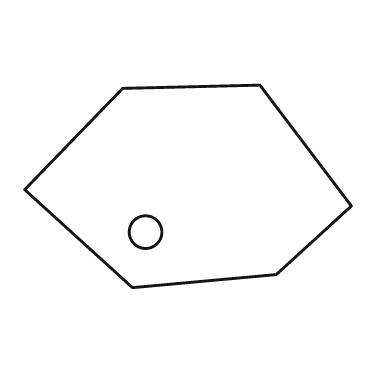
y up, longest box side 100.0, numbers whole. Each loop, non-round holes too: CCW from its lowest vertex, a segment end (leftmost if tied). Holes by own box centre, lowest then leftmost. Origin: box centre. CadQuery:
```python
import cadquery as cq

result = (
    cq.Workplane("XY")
    .moveTo(-17.0, -31.0)
    .lineTo(27.0, -27.0)
    .lineTo(50.0, -6.0)
    .lineTo(22.0, 31.0)
    .lineTo(-20.0, 30.0)
    .lineTo(-50.0, -1.0)
    .close()
    .moveTo(-13.0, -14.0)
    .circle(5.0)
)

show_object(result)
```